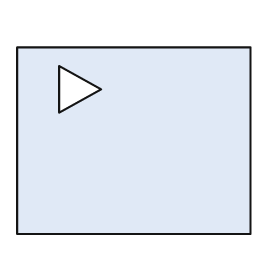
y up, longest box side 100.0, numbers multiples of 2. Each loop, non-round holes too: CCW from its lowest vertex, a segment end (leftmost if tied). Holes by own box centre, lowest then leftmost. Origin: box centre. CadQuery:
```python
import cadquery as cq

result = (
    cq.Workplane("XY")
    .moveTo(-50.0, -40.0)
    .lineTo(50.0, -40.0)
    .lineTo(50.0, 40.0)
    .lineTo(-50.0, 40.0)
    .close()
    .moveTo(-32.0, 12.0)
    .lineTo(-14.0, 22.0)
    .lineTo(-32.0, 32.0)
    .close()
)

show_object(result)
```